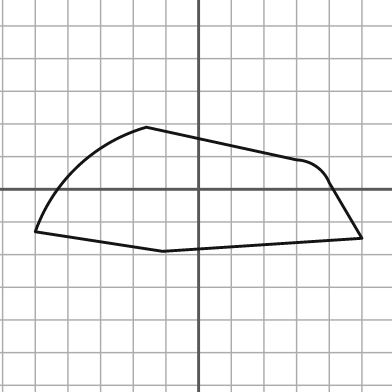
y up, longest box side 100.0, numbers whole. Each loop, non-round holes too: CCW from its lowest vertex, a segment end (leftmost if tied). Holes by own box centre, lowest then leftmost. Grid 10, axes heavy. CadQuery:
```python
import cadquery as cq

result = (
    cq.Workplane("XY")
    .moveTo(-11.0, -19.0)
    .lineTo(50.0, -15.0)
    .lineTo(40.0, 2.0)
    .threePointArc((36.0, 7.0), (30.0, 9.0))
    .lineTo(-16.0, 19.0)
    .threePointArc((-37.0, 7.0), (-50.0, -13.0))
    .close()
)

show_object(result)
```